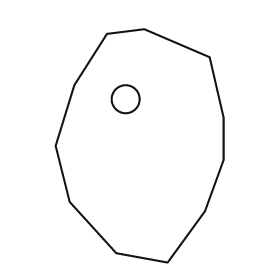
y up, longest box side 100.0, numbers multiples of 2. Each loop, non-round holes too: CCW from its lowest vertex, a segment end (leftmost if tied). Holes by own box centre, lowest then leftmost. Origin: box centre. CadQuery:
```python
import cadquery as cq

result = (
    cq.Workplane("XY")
    .moveTo(12.0, -50.0)
    .lineTo(28.0, -28.0)
    .lineTo(36.0, -6.0)
    .lineTo(36.0, 12.0)
    .lineTo(30.0, 38.0)
    .lineTo(2.0, 50.0)
    .lineTo(-14.0, 48.0)
    .lineTo(-28.0, 26.0)
    .lineTo(-36.0, 0.0)
    .lineTo(-30.0, -24.0)
    .lineTo(-10.0, -46.0)
    .close()
    .moveTo(-6.0, 20.0)
    .circle(6.0)
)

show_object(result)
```